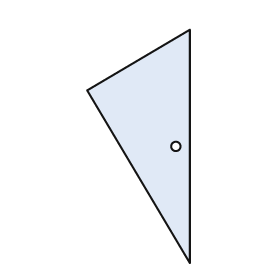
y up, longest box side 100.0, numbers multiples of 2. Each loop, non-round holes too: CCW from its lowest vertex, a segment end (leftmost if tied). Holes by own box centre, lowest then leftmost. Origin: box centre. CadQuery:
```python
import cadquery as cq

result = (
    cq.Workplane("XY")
    .moveTo(22.0, -50.0)
    .lineTo(22.0, 50.0)
    .lineTo(-22.0, 24.0)
    .close()
    .moveTo(16.0, 0.0)
    .circle(2.0)
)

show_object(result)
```